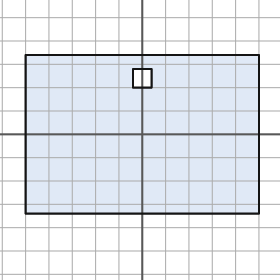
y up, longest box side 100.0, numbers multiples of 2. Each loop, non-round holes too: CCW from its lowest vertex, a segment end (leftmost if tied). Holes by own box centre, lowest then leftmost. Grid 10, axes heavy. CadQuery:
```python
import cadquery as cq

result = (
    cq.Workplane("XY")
    .moveTo(-50.0, -34.0)
    .lineTo(50.0, -34.0)
    .lineTo(50.0, 34.0)
    .lineTo(-50.0, 34.0)
    .close()
    .moveTo(-4.0, 20.0)
    .lineTo(4.0, 20.0)
    .lineTo(4.0, 28.0)
    .lineTo(-4.0, 28.0)
    .close()
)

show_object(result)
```